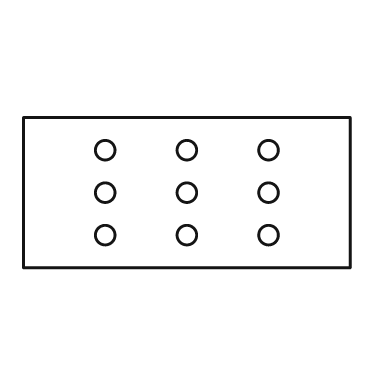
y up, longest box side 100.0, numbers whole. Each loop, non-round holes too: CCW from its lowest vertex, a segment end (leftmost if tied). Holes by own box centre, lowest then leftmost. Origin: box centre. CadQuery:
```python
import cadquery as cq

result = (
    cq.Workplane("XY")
    .moveTo(-50.0, -23.0)
    .lineTo(50.0, -23.0)
    .lineTo(50.0, 23.0)
    .lineTo(-50.0, 23.0)
    .close()
    .moveTo(-25.0, -13.0)
    .circle(3.0)
    .moveTo(0.0, -13.0)
    .circle(3.0)
    .moveTo(25.0, -13.0)
    .circle(3.0)
    .moveTo(-25.0, 0.0)
    .circle(3.0)
    .moveTo(0.0, 0.0)
    .circle(3.0)
    .moveTo(25.0, 0.0)
    .circle(3.0)
    .moveTo(-25.0, 13.0)
    .circle(3.0)
    .moveTo(0.0, 13.0)
    .circle(3.0)
    .moveTo(25.0, 13.0)
    .circle(3.0)
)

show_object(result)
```